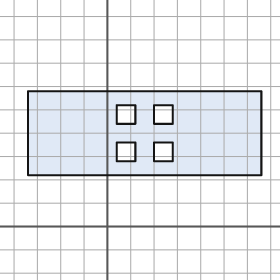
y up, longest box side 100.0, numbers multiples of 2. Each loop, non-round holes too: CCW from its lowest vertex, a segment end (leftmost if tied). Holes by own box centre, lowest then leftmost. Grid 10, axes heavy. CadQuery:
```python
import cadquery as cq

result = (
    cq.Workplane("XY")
    .moveTo(-34.0, 22.0)
    .lineTo(66.0, 22.0)
    .lineTo(66.0, 58.0)
    .lineTo(-34.0, 58.0)
    .close()
    .moveTo(4.0, 28.0)
    .lineTo(12.0, 28.0)
    .lineTo(12.0, 36.0)
    .lineTo(4.0, 36.0)
    .close()
    .moveTo(20.0, 28.0)
    .lineTo(28.0, 28.0)
    .lineTo(28.0, 36.0)
    .lineTo(20.0, 36.0)
    .close()
    .moveTo(4.0, 44.0)
    .lineTo(12.0, 44.0)
    .lineTo(12.0, 52.0)
    .lineTo(4.0, 52.0)
    .close()
    .moveTo(20.0, 44.0)
    .lineTo(28.0, 44.0)
    .lineTo(28.0, 52.0)
    .lineTo(20.0, 52.0)
    .close()
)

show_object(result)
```